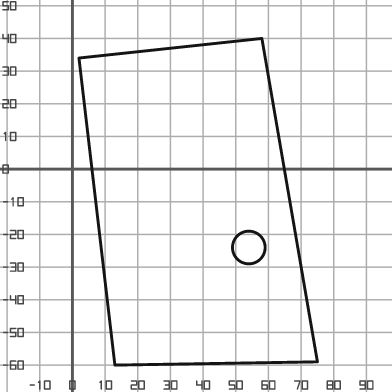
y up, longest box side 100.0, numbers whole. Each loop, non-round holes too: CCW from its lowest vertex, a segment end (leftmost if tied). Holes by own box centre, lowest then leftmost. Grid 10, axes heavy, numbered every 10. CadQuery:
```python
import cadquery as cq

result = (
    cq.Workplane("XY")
    .moveTo(13.0, -60.0)
    .lineTo(75.0, -59.0)
    .lineTo(58.0, 40.0)
    .lineTo(2.0, 34.0)
    .close()
    .moveTo(54.0, -24.0)
    .circle(5.0)
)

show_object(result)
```